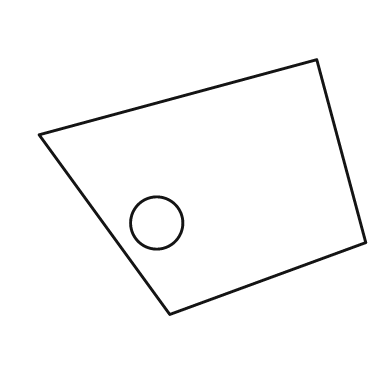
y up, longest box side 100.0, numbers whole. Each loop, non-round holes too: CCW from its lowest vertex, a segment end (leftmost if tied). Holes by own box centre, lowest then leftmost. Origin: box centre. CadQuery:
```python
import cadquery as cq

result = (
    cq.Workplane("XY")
    .moveTo(-10.0, -39.0)
    .lineTo(50.0, -17.0)
    .lineTo(35.0, 39.0)
    .lineTo(-50.0, 16.0)
    .close()
    .moveTo(-14.0, -11.0)
    .circle(8.0)
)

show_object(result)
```